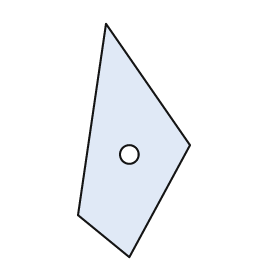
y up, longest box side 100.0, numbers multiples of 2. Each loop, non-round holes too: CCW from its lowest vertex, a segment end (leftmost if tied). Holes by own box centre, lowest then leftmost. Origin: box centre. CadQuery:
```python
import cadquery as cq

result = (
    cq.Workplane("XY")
    .moveTo(-2.0, -50.0)
    .lineTo(24.0, -2.0)
    .lineTo(-12.0, 50.0)
    .lineTo(-24.0, -32.0)
    .close()
    .moveTo(-2.0, -6.0)
    .circle(4.0)
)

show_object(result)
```